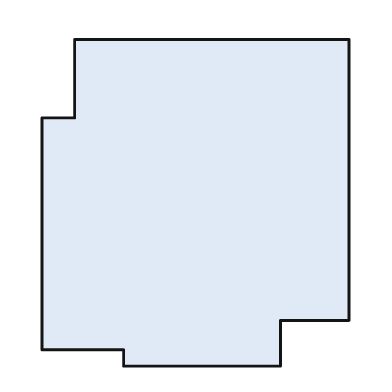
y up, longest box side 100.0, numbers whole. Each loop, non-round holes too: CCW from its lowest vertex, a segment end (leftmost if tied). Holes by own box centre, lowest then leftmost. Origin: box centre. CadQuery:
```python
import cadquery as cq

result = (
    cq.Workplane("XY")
    .moveTo(-22.0, -50.0)
    .lineTo(26.0, -50.0)
    .lineTo(26.0, -36.0)
    .lineTo(47.0, -36.0)
    .lineTo(47.0, 50.0)
    .lineTo(-37.0, 50.0)
    .lineTo(-37.0, 26.0)
    .lineTo(-47.0, 26.0)
    .lineTo(-47.0, -45.0)
    .lineTo(-22.0, -45.0)
    .close()
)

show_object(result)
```